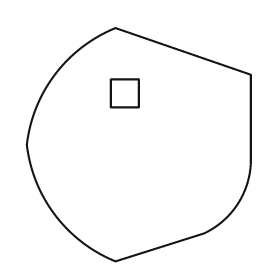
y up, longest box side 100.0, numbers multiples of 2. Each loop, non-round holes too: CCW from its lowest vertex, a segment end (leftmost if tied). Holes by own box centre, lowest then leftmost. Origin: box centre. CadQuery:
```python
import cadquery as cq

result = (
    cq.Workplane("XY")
    .moveTo(-10.0, -50.0)
    .lineTo(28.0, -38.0)
    .threePointArc((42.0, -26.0), (48.0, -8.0))
    .lineTo(48.0, 30.0)
    .lineTo(-10.0, 50.0)
    .threePointArc((-36.0, 30.0), (-48.0, 0.0))
    .threePointArc((-36.0, -30.0), (-10.0, -50.0))
    .close()
    .moveTo(-12.0, 16.0)
    .lineTo(0.0, 16.0)
    .lineTo(0.0, 28.0)
    .lineTo(-12.0, 28.0)
    .close()
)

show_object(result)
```